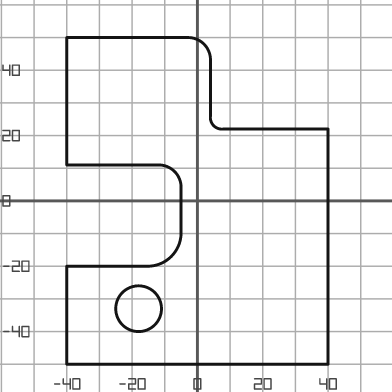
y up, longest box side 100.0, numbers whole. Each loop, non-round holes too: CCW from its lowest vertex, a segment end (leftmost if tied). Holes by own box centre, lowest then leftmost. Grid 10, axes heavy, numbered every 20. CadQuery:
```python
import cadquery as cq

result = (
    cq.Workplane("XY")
    .moveTo(-40.0, -50.0)
    .lineTo(40.0, -50.0)
    .lineTo(40.0, 22.0)
    .lineTo(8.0, 22.0)
    .threePointArc((5.0, 23.0), (4.0, 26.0))
    .lineTo(4.0, 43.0)
    .threePointArc((2.0, 48.0), (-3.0, 50.0))
    .lineTo(-40.0, 50.0)
    .lineTo(-40.0, 11.0)
    .lineTo(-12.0, 11.0)
    .threePointArc((-7.0, 9.0), (-5.0, 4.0))
    .lineTo(-5.0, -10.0)
    .threePointArc((-8.0, -17.0), (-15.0, -20.0))
    .lineTo(-40.0, -20.0)
    .close()
    .moveTo(-18.0, -33.0)
    .circle(7.0)
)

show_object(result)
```